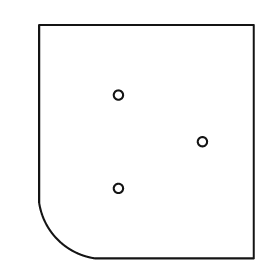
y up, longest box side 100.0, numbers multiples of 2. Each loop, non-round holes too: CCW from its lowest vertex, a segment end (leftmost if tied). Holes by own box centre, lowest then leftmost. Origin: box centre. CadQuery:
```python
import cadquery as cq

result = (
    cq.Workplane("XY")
    .moveTo(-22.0, -50.0)
    .lineTo(46.0, -50.0)
    .lineTo(46.0, 50.0)
    .lineTo(-46.0, 50.0)
    .lineTo(-46.0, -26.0)
    .threePointArc((-38.0, -42.0), (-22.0, -50.0))
    .close()
    .moveTo(-12.0, -20.0)
    .circle(2.0)
    .moveTo(24.0, 0.0)
    .circle(2.0)
    .moveTo(-12.0, 20.0)
    .circle(2.0)
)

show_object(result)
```